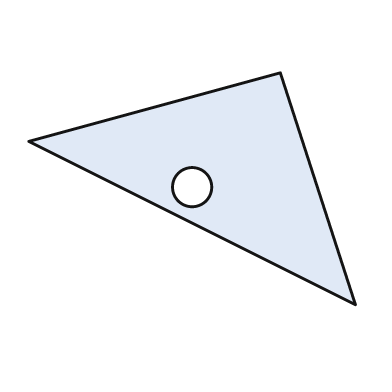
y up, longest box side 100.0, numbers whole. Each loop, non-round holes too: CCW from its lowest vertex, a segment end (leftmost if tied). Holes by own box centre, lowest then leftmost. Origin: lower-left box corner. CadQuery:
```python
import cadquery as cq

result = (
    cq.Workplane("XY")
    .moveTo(100.0, 0.0)
    .lineTo(77.0, 71.0)
    .lineTo(0.0, 50.0)
    .close()
    .moveTo(50.0, 36.0)
    .circle(6.0)
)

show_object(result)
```